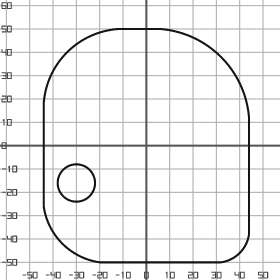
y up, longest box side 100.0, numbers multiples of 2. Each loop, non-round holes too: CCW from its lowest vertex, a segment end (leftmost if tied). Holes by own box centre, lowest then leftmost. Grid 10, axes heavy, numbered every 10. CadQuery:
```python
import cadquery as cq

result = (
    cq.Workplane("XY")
    .moveTo(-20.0, -50.0)
    .lineTo(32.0, -50.0)
    .threePointArc((40.0, -46.0), (44.0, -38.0))
    .lineTo(44.0, 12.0)
    .threePointArc((32.0, 38.0), (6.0, 50.0))
    .lineTo(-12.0, 50.0)
    .threePointArc((-34.0, 40.0), (-44.0, 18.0))
    .lineTo(-44.0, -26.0)
    .threePointArc((-36.0, -42.0), (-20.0, -50.0))
    .close()
    .moveTo(-30.0, -16.0)
    .circle(8.0)
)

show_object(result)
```